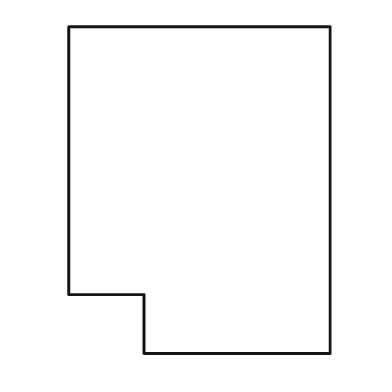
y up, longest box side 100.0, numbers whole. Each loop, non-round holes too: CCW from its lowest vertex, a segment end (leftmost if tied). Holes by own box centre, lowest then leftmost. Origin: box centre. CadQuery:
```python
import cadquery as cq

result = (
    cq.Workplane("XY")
    .moveTo(-17.0, -50.0)
    .lineTo(40.0, -50.0)
    .lineTo(40.0, 50.0)
    .lineTo(-40.0, 50.0)
    .lineTo(-40.0, -32.0)
    .lineTo(-17.0, -32.0)
    .close()
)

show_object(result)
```